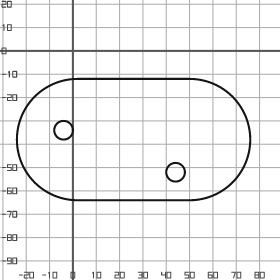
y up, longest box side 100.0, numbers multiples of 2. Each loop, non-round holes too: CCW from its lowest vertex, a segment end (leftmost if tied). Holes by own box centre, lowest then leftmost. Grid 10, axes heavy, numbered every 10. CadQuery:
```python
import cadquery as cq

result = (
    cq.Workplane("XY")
    .moveTo(2.0, -64.0)
    .lineTo(50.0, -64.0)
    .threePointArc((76.0, -38.0), (50.0, -12.0))
    .lineTo(2.0, -12.0)
    .threePointArc((-24.0, -38.0), (2.0, -64.0))
    .close()
    .moveTo(44.0, -52.0)
    .circle(4.0)
    .moveTo(-4.0, -34.0)
    .circle(4.0)
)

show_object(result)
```